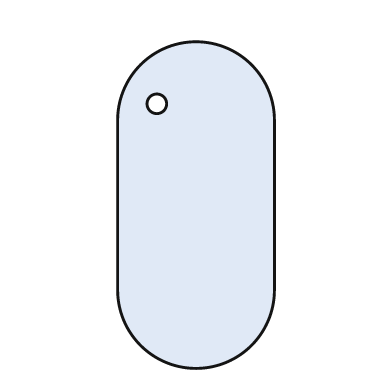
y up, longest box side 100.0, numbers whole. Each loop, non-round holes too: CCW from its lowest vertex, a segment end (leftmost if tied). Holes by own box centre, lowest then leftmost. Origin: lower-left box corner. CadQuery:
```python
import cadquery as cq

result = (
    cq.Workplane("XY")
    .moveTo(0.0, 24.0)
    .threePointArc((24.0, 0.0), (48.0, 24.0))
    .lineTo(48.0, 76.0)
    .threePointArc((24.0, 100.0), (0.0, 76.0))
    .close()
    .moveTo(12.0, 81.0)
    .circle(3.0)
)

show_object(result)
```